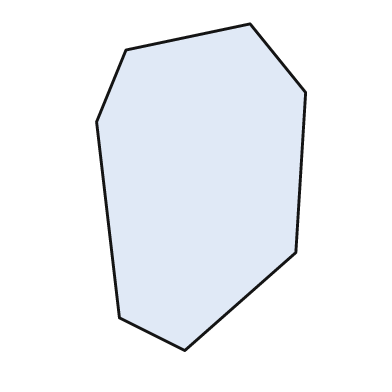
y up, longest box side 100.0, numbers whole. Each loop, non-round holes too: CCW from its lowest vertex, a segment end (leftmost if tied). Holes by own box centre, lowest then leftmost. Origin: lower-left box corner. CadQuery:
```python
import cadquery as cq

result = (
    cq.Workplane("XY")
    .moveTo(27.0, 0.0)
    .lineTo(61.0, 30.0)
    .lineTo(64.0, 79.0)
    .lineTo(47.0, 100.0)
    .lineTo(9.0, 92.0)
    .lineTo(0.0, 70.0)
    .lineTo(7.0, 10.0)
    .close()
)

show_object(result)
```